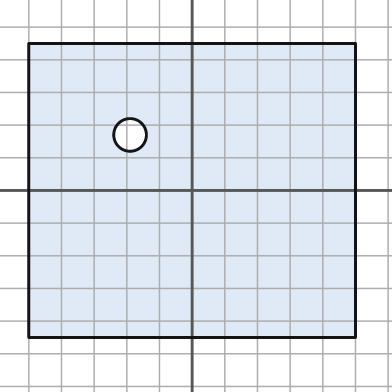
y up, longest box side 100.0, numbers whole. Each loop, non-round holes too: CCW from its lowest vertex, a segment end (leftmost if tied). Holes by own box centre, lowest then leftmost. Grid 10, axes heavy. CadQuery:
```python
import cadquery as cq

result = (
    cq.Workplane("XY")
    .moveTo(-50.0, -45.0)
    .lineTo(50.0, -45.0)
    .lineTo(50.0, 45.0)
    .lineTo(-50.0, 45.0)
    .close()
    .moveTo(-19.0, 17.0)
    .circle(5.0)
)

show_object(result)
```